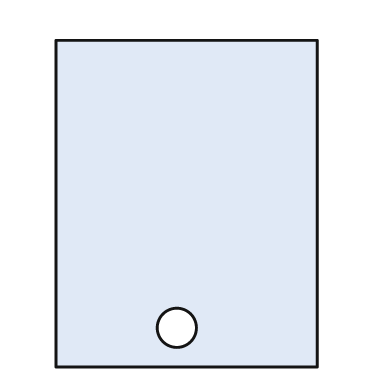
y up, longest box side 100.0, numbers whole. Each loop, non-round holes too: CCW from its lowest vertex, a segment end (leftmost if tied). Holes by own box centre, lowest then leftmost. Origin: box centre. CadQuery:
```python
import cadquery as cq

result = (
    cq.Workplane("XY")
    .moveTo(-40.0, -50.0)
    .lineTo(40.0, -50.0)
    .lineTo(40.0, 50.0)
    .lineTo(-40.0, 50.0)
    .close()
    .moveTo(-3.0, -38.0)
    .circle(6.0)
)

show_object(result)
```